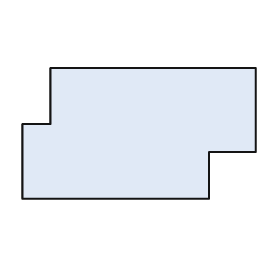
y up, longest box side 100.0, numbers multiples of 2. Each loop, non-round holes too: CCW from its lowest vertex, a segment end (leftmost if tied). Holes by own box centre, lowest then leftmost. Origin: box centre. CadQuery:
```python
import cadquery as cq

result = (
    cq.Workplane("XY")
    .moveTo(-50.0, -28.0)
    .lineTo(30.0, -28.0)
    .lineTo(30.0, -8.0)
    .lineTo(50.0, -8.0)
    .lineTo(50.0, 28.0)
    .lineTo(-38.0, 28.0)
    .lineTo(-38.0, 4.0)
    .lineTo(-50.0, 4.0)
    .close()
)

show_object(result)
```